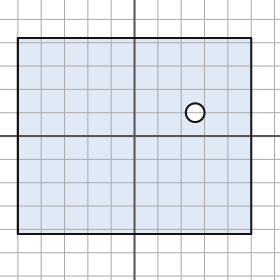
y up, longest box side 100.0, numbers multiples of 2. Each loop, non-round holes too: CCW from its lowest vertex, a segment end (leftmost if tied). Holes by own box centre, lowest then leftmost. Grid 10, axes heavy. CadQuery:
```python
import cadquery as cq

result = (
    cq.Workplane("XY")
    .moveTo(-50.0, -42.0)
    .lineTo(50.0, -42.0)
    .lineTo(50.0, 42.0)
    .lineTo(-50.0, 42.0)
    .close()
    .moveTo(26.0, 10.0)
    .circle(4.0)
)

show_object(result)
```